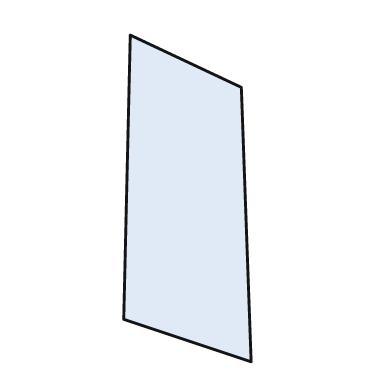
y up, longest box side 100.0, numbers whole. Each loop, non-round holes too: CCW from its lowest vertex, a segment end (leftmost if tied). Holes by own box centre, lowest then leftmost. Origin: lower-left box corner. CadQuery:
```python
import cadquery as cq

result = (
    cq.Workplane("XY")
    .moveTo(39.0, 0.0)
    .lineTo(36.0, 84.0)
    .lineTo(2.0, 100.0)
    .lineTo(0.0, 13.0)
    .close()
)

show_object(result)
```